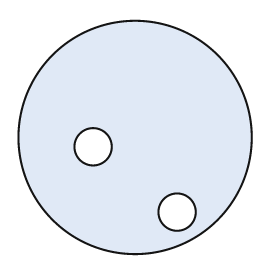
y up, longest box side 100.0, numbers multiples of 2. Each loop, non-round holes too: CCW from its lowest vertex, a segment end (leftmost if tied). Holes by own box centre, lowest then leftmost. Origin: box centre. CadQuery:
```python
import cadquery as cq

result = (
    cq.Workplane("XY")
    .moveTo(0.0, 0.0)
    .circle(50.0)
    .moveTo(18.0, -32.0)
    .circle(8.0)
    .moveTo(-18.0, -4.0)
    .circle(8.0)
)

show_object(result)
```